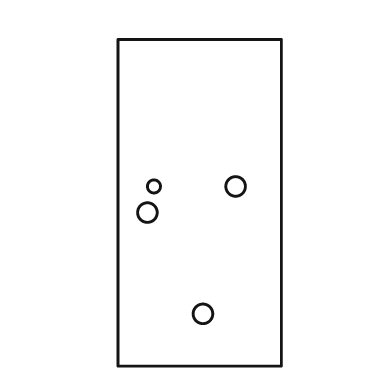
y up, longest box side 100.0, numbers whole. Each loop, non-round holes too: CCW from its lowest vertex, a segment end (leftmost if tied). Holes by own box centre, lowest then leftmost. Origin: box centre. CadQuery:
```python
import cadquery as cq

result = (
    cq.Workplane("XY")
    .moveTo(-25.0, -50.0)
    .lineTo(25.0, -50.0)
    .lineTo(25.0, 50.0)
    .lineTo(-25.0, 50.0)
    .close()
    .moveTo(1.0, -34.0)
    .circle(3.0)
    .moveTo(-16.0, -3.0)
    .circle(3.0)
    .moveTo(-14.0, 5.0)
    .circle(2.0)
    .moveTo(11.0, 5.0)
    .circle(3.0)
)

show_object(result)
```